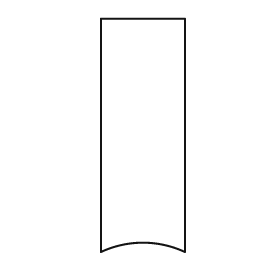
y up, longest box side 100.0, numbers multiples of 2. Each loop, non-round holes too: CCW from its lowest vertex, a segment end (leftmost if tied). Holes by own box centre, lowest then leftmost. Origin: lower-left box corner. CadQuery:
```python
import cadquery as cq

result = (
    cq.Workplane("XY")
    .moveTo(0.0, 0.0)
    .threePointArc((18.0, 4.0), (36.0, 0.0))
    .lineTo(36.0, 100.0)
    .lineTo(0.0, 100.0)
    .close()
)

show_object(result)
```